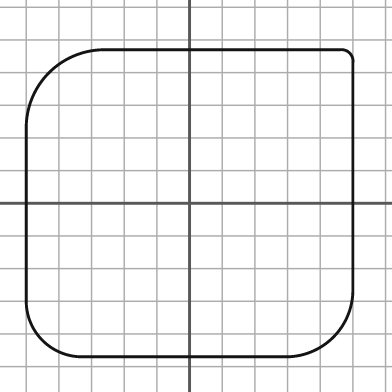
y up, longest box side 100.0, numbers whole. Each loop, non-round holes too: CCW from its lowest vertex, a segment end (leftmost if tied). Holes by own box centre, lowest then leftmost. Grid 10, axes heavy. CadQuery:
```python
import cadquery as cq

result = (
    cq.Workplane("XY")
    .moveTo(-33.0, -47.0)
    .lineTo(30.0, -47.0)
    .threePointArc((44.0, -41.0), (50.0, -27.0))
    .lineTo(50.0, 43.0)
    .threePointArc((49.0, 46.0), (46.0, 47.0))
    .lineTo(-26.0, 47.0)
    .threePointArc((-43.0, 40.0), (-50.0, 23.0))
    .lineTo(-50.0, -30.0)
    .threePointArc((-45.0, -42.0), (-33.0, -47.0))
    .close()
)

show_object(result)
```